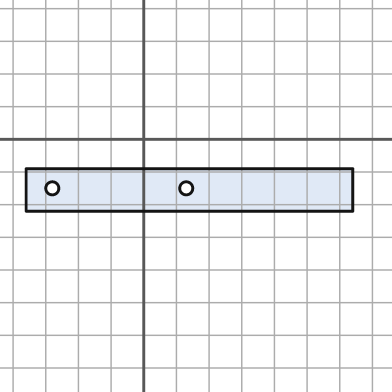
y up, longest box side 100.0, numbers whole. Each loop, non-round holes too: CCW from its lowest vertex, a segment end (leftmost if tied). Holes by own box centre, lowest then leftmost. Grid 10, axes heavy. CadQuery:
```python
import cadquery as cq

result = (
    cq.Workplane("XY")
    .moveTo(-36.0, -22.0)
    .lineTo(64.0, -22.0)
    .lineTo(64.0, -9.0)
    .lineTo(-36.0, -9.0)
    .close()
    .moveTo(-28.0, -15.0)
    .circle(2.0)
    .moveTo(13.0, -15.0)
    .circle(2.0)
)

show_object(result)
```